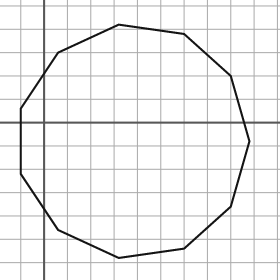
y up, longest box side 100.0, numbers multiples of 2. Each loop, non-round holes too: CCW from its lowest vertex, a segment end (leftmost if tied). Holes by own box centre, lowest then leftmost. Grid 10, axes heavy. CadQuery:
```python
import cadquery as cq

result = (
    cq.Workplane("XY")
    .moveTo(32.0, -58.0)
    .lineTo(60.0, -54.0)
    .lineTo(80.0, -36.0)
    .lineTo(88.0, -8.0)
    .lineTo(80.0, 20.0)
    .lineTo(60.0, 38.0)
    .lineTo(32.0, 42.0)
    .lineTo(6.0, 30.0)
    .lineTo(-10.0, 6.0)
    .lineTo(-10.0, -22.0)
    .lineTo(6.0, -46.0)
    .close()
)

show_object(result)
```